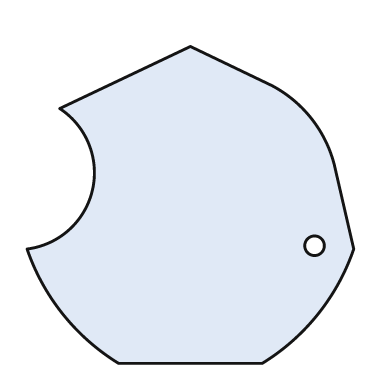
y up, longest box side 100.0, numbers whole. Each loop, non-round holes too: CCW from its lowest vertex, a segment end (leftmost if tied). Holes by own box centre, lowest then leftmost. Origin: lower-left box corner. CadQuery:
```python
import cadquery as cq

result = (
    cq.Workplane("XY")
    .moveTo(28.0, 0.0)
    .lineTo(72.0, 0.0)
    .threePointArc((89.0, 15.0), (100.0, 35.0))
    .lineTo(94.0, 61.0)
    .threePointArc((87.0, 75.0), (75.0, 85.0))
    .lineTo(50.0, 97.0)
    .lineTo(10.0, 78.0)
    .threePointArc((20.0, 53.0), (0.0, 35.0))
    .threePointArc((11.0, 15.0), (28.0, 0.0))
    .close()
    .moveTo(88.0, 36.0)
    .circle(3.0)
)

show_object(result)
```